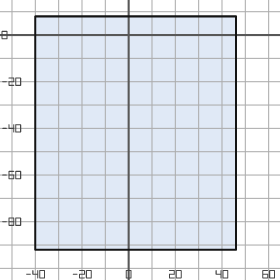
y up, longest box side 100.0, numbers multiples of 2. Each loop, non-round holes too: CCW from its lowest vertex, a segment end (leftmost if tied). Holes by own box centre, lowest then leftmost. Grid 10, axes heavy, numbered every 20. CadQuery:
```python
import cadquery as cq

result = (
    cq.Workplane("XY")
    .moveTo(-40.0, -92.0)
    .lineTo(46.0, -92.0)
    .lineTo(46.0, 8.0)
    .lineTo(-40.0, 8.0)
    .close()
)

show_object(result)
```